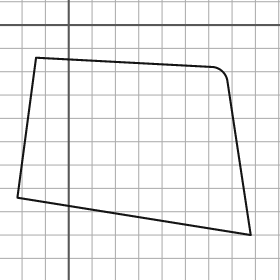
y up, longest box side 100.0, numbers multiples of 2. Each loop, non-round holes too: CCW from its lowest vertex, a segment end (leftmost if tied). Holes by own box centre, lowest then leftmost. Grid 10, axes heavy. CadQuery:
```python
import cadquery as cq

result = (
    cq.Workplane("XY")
    .moveTo(78.0, -90.0)
    .lineTo(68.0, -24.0)
    .threePointArc((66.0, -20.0), (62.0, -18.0))
    .lineTo(-14.0, -14.0)
    .lineTo(-22.0, -74.0)
    .close()
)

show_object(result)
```